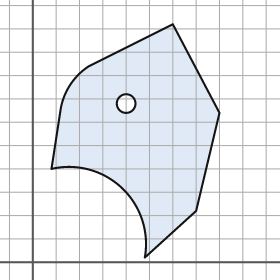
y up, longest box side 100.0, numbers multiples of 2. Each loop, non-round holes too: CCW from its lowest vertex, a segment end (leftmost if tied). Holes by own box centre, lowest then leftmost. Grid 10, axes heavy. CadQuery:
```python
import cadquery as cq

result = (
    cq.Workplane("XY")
    .moveTo(48.0, 2.0)
    .lineTo(70.0, 22.0)
    .lineTo(80.0, 64.0)
    .lineTo(60.0, 102.0)
    .lineTo(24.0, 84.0)
    .threePointArc((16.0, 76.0), (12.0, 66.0))
    .lineTo(8.0, 40.0)
    .threePointArc((38.0, 32.0), (48.0, 2.0))
    .close()
    .moveTo(40.0, 68.0)
    .circle(4.0)
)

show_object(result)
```